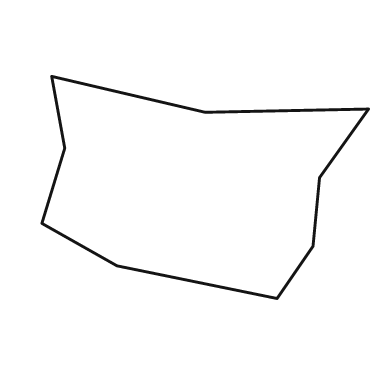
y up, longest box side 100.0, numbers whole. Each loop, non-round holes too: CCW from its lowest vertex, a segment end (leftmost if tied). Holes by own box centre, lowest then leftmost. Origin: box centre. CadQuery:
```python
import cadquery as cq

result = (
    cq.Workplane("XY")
    .moveTo(22.0, -34.0)
    .lineTo(33.0, -18.0)
    .lineTo(35.0, 3.0)
    .lineTo(50.0, 24.0)
    .lineTo(0.0, 23.0)
    .lineTo(-47.0, 34.0)
    .lineTo(-43.0, 12.0)
    .lineTo(-50.0, -11.0)
    .lineTo(-27.0, -24.0)
    .close()
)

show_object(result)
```